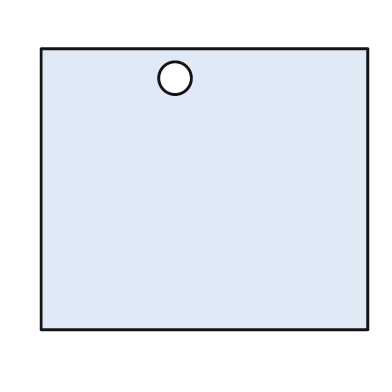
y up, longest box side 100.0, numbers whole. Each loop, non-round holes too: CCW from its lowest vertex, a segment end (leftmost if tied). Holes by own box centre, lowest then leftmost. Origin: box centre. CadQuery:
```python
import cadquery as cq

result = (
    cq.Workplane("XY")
    .moveTo(-50.0, -43.0)
    .lineTo(50.0, -43.0)
    .lineTo(50.0, 43.0)
    .lineTo(-50.0, 43.0)
    .close()
    .moveTo(-9.0, 34.0)
    .circle(5.0)
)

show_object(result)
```